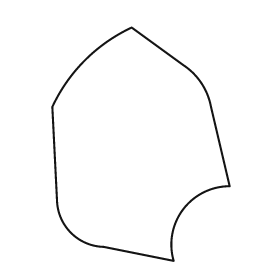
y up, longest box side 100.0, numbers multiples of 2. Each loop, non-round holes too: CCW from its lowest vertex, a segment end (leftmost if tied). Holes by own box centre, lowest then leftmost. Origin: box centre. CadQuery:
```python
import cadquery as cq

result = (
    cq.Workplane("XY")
    .moveTo(14.0, -50.0)
    .threePointArc((18.0, -28.0), (38.0, -18.0))
    .lineTo(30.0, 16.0)
    .threePointArc((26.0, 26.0), (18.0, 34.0))
    .lineTo(-4.0, 50.0)
    .threePointArc((-24.0, 36.0), (-38.0, 16.0))
    .lineTo(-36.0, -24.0)
    .threePointArc((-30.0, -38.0), (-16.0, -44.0))
    .close()
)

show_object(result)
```